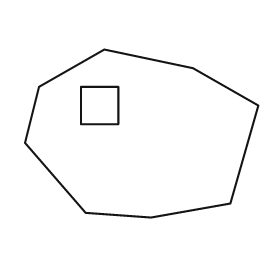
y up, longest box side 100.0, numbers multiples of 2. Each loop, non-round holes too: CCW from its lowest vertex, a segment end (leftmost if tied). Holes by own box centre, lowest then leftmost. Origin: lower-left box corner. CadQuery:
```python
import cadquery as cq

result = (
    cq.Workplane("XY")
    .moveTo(54.0, 0.0)
    .lineTo(88.0, 6.0)
    .lineTo(100.0, 48.0)
    .lineTo(72.0, 64.0)
    .lineTo(34.0, 72.0)
    .lineTo(6.0, 56.0)
    .lineTo(0.0, 32.0)
    .lineTo(26.0, 2.0)
    .close()
    .moveTo(24.0, 40.0)
    .lineTo(40.0, 40.0)
    .lineTo(40.0, 56.0)
    .lineTo(24.0, 56.0)
    .close()
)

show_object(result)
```